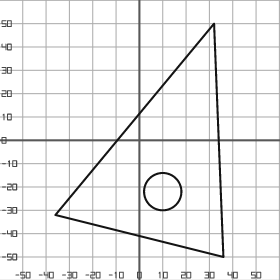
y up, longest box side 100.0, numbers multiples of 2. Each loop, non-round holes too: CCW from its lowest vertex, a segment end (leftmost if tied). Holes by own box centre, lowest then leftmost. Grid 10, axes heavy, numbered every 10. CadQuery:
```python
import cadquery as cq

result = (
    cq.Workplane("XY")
    .moveTo(36.0, -50.0)
    .lineTo(32.0, 50.0)
    .lineTo(-36.0, -32.0)
    .close()
    .moveTo(10.0, -22.0)
    .circle(8.0)
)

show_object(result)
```